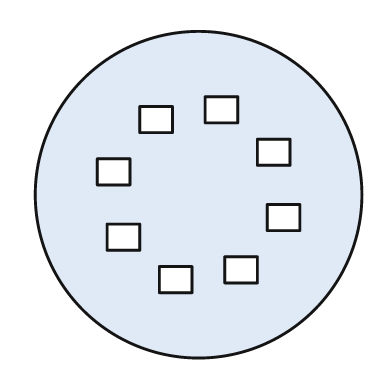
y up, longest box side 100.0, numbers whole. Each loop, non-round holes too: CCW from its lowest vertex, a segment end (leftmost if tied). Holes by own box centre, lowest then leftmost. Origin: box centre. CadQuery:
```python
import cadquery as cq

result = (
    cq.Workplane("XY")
    .moveTo(0.0, 0.0)
    .circle(50.0)
    .moveTo(-12.0, -30.0)
    .lineTo(-2.0, -30.0)
    .lineTo(-2.0, -22.0)
    .lineTo(-12.0, -22.0)
    .close()
    .moveTo(8.0, -27.0)
    .lineTo(18.0, -27.0)
    .lineTo(18.0, -19.0)
    .lineTo(8.0, -19.0)
    .close()
    .moveTo(-28.0, -17.0)
    .lineTo(-18.0, -17.0)
    .lineTo(-18.0, -9.0)
    .lineTo(-28.0, -9.0)
    .close()
    .moveTo(21.0, -11.0)
    .lineTo(31.0, -11.0)
    .lineTo(31.0, -3.0)
    .lineTo(21.0, -3.0)
    .close()
    .moveTo(-31.0, 3.0)
    .lineTo(-21.0, 3.0)
    .lineTo(-21.0, 11.0)
    .lineTo(-31.0, 11.0)
    .close()
    .moveTo(18.0, 9.0)
    .lineTo(28.0, 9.0)
    .lineTo(28.0, 17.0)
    .lineTo(18.0, 17.0)
    .close()
    .moveTo(-18.0, 19.0)
    .lineTo(-8.0, 19.0)
    .lineTo(-8.0, 27.0)
    .lineTo(-18.0, 27.0)
    .close()
    .moveTo(2.0, 22.0)
    .lineTo(12.0, 22.0)
    .lineTo(12.0, 30.0)
    .lineTo(2.0, 30.0)
    .close()
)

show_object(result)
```